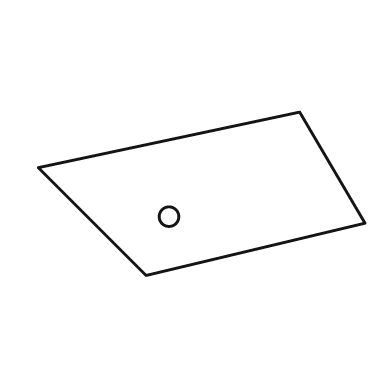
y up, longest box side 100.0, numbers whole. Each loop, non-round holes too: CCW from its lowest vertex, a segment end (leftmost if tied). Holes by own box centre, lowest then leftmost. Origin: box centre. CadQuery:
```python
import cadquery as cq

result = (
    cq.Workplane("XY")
    .moveTo(-17.0, -25.0)
    .lineTo(50.0, -9.0)
    .lineTo(30.0, 25.0)
    .lineTo(-50.0, 8.0)
    .close()
    .moveTo(-10.0, -7.0)
    .circle(3.0)
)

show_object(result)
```